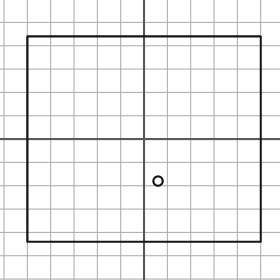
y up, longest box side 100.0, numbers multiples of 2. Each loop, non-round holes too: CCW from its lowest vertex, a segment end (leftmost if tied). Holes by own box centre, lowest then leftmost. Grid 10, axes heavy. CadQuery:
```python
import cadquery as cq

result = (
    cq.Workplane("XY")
    .moveTo(-50.0, -44.0)
    .lineTo(50.0, -44.0)
    .lineTo(50.0, 44.0)
    .lineTo(-50.0, 44.0)
    .close()
    .moveTo(6.0, -18.0)
    .circle(2.0)
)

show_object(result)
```